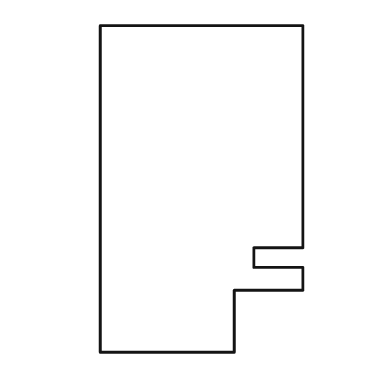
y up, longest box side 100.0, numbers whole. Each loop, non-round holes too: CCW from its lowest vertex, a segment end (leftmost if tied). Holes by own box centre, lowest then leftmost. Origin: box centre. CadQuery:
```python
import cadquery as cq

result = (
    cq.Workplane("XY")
    .moveTo(-31.0, -50.0)
    .lineTo(10.0, -50.0)
    .lineTo(10.0, -31.0)
    .lineTo(31.0, -31.0)
    .lineTo(31.0, -24.0)
    .lineTo(16.0, -24.0)
    .lineTo(16.0, -18.0)
    .lineTo(31.0, -18.0)
    .lineTo(31.0, 50.0)
    .lineTo(-31.0, 50.0)
    .close()
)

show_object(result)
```